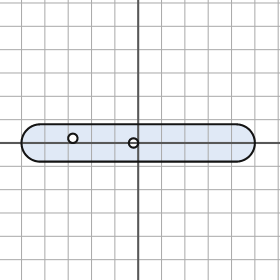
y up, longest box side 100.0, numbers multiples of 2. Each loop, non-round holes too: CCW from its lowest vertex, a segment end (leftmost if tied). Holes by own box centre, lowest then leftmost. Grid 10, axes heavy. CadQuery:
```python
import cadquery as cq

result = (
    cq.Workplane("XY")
    .moveTo(-42.0, -8.0)
    .lineTo(42.0, -8.0)
    .threePointArc((50.0, 0.0), (42.0, 8.0))
    .lineTo(-42.0, 8.0)
    .threePointArc((-50.0, 0.0), (-42.0, -8.0))
    .close()
    .moveTo(-2.0, 0.0)
    .circle(2.0)
    .moveTo(-28.0, 2.0)
    .circle(2.0)
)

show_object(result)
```